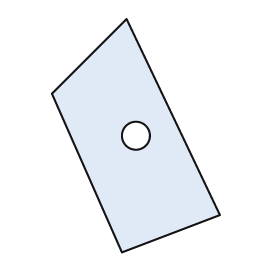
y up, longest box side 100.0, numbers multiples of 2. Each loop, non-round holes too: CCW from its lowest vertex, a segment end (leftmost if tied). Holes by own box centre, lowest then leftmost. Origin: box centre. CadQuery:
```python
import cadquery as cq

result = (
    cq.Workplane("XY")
    .moveTo(-6.0, -50.0)
    .lineTo(36.0, -34.0)
    .lineTo(-4.0, 50.0)
    .lineTo(-36.0, 18.0)
    .close()
    .moveTo(0.0, 0.0)
    .circle(6.0)
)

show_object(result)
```